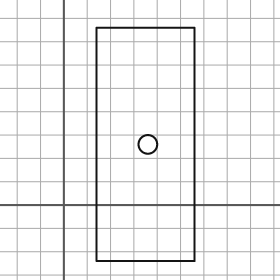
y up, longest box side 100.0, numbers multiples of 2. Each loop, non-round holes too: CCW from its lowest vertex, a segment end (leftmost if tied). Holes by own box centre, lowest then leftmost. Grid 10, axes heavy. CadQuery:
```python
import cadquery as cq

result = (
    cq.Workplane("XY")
    .moveTo(14.0, -24.0)
    .lineTo(56.0, -24.0)
    .lineTo(56.0, 76.0)
    .lineTo(14.0, 76.0)
    .close()
    .moveTo(36.0, 26.0)
    .circle(4.0)
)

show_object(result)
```